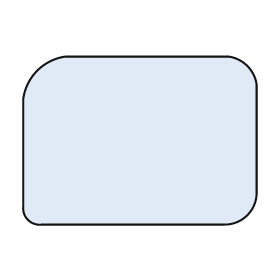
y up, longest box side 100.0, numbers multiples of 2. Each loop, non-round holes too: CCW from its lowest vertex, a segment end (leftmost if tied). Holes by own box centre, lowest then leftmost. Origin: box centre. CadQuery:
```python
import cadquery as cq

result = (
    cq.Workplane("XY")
    .moveTo(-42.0, -36.0)
    .lineTo(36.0, -36.0)
    .threePointArc((46.0, -32.0), (50.0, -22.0))
    .lineTo(50.0, 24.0)
    .threePointArc((46.0, 32.0), (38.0, 36.0))
    .lineTo(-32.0, 36.0)
    .threePointArc((-44.0, 30.0), (-50.0, 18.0))
    .lineTo(-50.0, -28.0)
    .threePointArc((-48.0, -34.0), (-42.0, -36.0))
    .close()
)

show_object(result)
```